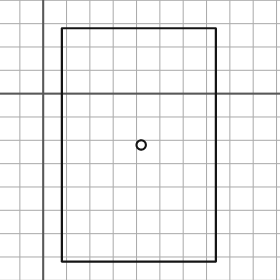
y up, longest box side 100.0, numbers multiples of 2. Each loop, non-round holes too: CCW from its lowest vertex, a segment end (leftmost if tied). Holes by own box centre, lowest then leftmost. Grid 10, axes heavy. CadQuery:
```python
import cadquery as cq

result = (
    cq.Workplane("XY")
    .moveTo(8.0, -72.0)
    .lineTo(74.0, -72.0)
    .lineTo(74.0, 28.0)
    .lineTo(8.0, 28.0)
    .close()
    .moveTo(42.0, -22.0)
    .circle(2.0)
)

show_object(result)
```